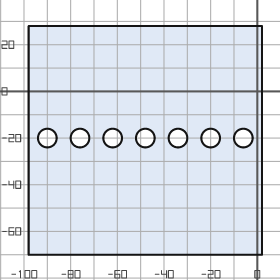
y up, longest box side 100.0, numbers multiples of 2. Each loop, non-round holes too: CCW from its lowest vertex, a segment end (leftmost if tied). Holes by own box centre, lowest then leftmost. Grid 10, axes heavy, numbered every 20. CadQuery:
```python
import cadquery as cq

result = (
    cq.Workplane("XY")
    .moveTo(-98.0, -70.0)
    .lineTo(2.0, -70.0)
    .lineTo(2.0, 28.0)
    .lineTo(-98.0, 28.0)
    .close()
    .moveTo(-90.0, -20.0)
    .circle(4.0)
    .moveTo(-76.0, -20.0)
    .circle(4.0)
    .moveTo(-62.0, -20.0)
    .circle(4.0)
    .moveTo(-48.0, -20.0)
    .circle(4.0)
    .moveTo(-34.0, -20.0)
    .circle(4.0)
    .moveTo(-20.0, -20.0)
    .circle(4.0)
    .moveTo(-6.0, -20.0)
    .circle(4.0)
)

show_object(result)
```